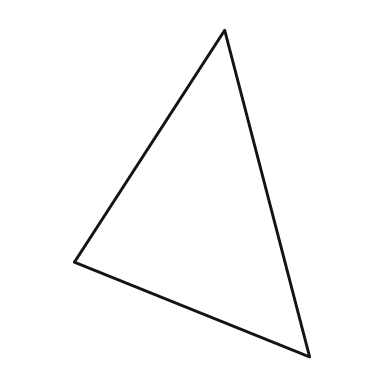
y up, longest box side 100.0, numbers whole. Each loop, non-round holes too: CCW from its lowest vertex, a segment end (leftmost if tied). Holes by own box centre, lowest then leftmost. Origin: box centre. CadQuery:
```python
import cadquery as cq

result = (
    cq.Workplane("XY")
    .moveTo(36.0, -50.0)
    .lineTo(10.0, 50.0)
    .lineTo(-36.0, -21.0)
    .close()
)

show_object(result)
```